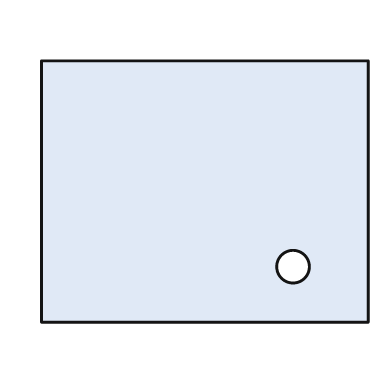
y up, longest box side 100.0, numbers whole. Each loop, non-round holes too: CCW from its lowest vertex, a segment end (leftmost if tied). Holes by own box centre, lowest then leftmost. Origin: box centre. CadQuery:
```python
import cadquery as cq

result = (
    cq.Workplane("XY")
    .moveTo(-50.0, -40.0)
    .lineTo(50.0, -40.0)
    .lineTo(50.0, 40.0)
    .lineTo(-50.0, 40.0)
    .close()
    .moveTo(27.0, -23.0)
    .circle(5.0)
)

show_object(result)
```